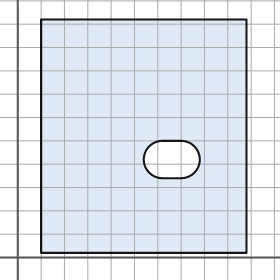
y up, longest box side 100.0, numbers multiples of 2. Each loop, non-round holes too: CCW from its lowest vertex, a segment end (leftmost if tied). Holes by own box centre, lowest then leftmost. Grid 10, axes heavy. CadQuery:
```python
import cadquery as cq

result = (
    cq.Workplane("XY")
    .moveTo(10.0, 2.0)
    .lineTo(98.0, 2.0)
    .lineTo(98.0, 102.0)
    .lineTo(10.0, 102.0)
    .close()
    .moveTo(62.0, 34.0)
    .lineTo(70.0, 34.0)
    .threePointArc((78.0, 42.0), (70.0, 50.0))
    .lineTo(62.0, 50.0)
    .threePointArc((54.0, 42.0), (62.0, 34.0))
    .close()
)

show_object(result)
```